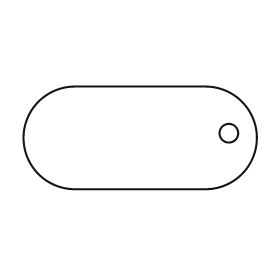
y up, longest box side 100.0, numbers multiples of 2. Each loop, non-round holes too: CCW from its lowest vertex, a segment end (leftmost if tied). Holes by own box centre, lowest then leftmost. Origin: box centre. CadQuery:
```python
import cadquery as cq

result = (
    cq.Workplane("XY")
    .moveTo(-28.0, -22.0)
    .lineTo(28.0, -22.0)
    .threePointArc((50.0, 0.0), (28.0, 22.0))
    .lineTo(-28.0, 22.0)
    .threePointArc((-50.0, 0.0), (-28.0, -22.0))
    .close()
    .moveTo(38.0, 2.0)
    .circle(4.0)
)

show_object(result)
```